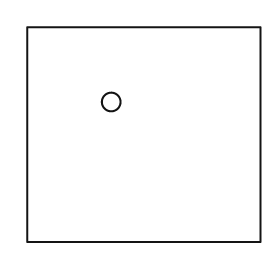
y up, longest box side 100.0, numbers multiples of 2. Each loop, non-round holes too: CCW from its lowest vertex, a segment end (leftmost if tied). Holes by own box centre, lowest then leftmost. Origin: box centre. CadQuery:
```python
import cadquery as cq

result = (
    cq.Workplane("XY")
    .moveTo(-50.0, -46.0)
    .lineTo(50.0, -46.0)
    .lineTo(50.0, 46.0)
    .lineTo(-50.0, 46.0)
    .close()
    .moveTo(-14.0, 14.0)
    .circle(4.0)
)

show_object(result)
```